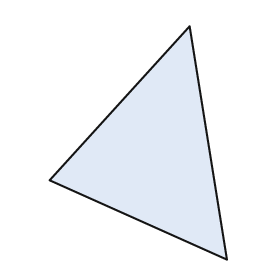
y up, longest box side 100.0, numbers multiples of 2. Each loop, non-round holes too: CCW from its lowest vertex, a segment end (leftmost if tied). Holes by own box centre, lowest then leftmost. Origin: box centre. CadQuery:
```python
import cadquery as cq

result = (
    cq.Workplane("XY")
    .moveTo(38.0, -50.0)
    .lineTo(22.0, 50.0)
    .lineTo(-38.0, -16.0)
    .close()
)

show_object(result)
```